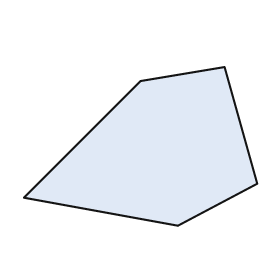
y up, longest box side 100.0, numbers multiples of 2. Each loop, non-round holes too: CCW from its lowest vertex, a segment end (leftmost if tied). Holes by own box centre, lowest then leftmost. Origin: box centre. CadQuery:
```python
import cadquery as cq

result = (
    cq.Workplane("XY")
    .moveTo(16.0, -34.0)
    .lineTo(50.0, -16.0)
    .lineTo(36.0, 34.0)
    .lineTo(0.0, 28.0)
    .lineTo(-50.0, -22.0)
    .close()
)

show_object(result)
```